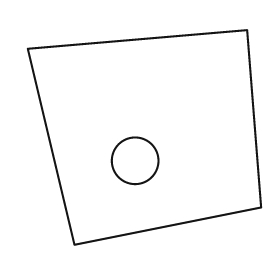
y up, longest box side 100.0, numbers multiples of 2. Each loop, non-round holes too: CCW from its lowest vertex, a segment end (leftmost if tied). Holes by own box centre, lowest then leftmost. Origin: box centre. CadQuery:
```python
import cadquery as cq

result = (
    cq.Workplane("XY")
    .moveTo(-30.0, -46.0)
    .lineTo(50.0, -30.0)
    .lineTo(44.0, 46.0)
    .lineTo(-50.0, 38.0)
    .close()
    .moveTo(-4.0, -10.0)
    .circle(10.0)
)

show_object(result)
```